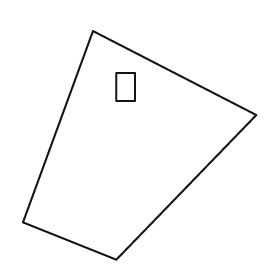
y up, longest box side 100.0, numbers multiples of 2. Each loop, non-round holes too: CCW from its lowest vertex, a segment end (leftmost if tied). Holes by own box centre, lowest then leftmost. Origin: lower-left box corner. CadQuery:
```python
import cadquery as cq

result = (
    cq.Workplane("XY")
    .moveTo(40.0, 0.0)
    .lineTo(100.0, 62.0)
    .lineTo(30.0, 98.0)
    .lineTo(0.0, 16.0)
    .close()
    .moveTo(40.0, 68.0)
    .lineTo(48.0, 68.0)
    .lineTo(48.0, 80.0)
    .lineTo(40.0, 80.0)
    .close()
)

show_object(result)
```